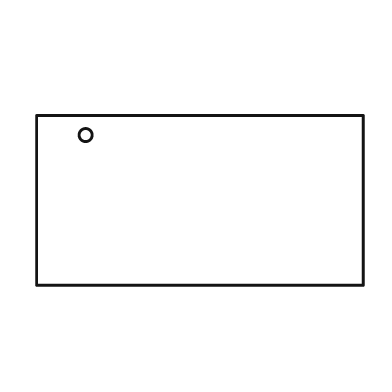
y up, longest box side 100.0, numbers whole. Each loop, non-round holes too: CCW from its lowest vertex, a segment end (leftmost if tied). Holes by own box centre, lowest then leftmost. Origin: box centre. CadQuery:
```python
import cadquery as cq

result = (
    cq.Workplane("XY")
    .moveTo(-50.0, -26.0)
    .lineTo(50.0, -26.0)
    .lineTo(50.0, 26.0)
    .lineTo(-50.0, 26.0)
    .close()
    .moveTo(-35.0, 20.0)
    .circle(2.0)
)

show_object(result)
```